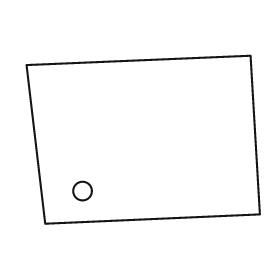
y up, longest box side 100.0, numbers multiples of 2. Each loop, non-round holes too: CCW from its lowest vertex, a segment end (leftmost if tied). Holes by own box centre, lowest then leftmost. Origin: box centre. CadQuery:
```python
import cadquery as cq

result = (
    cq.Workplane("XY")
    .moveTo(-42.0, -36.0)
    .lineTo(50.0, -32.0)
    .lineTo(46.0, 36.0)
    .lineTo(-50.0, 32.0)
    .close()
    .moveTo(-26.0, -22.0)
    .circle(4.0)
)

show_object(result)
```